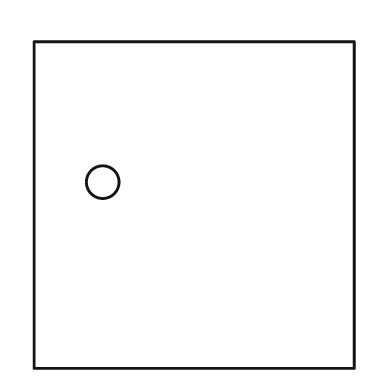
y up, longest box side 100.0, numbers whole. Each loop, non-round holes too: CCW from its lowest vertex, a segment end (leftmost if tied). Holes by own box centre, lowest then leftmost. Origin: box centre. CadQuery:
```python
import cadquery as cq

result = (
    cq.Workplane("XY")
    .moveTo(-49.0, -50.0)
    .lineTo(49.0, -50.0)
    .lineTo(49.0, 50.0)
    .lineTo(-49.0, 50.0)
    .close()
    .moveTo(-28.0, 7.0)
    .circle(5.0)
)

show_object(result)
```